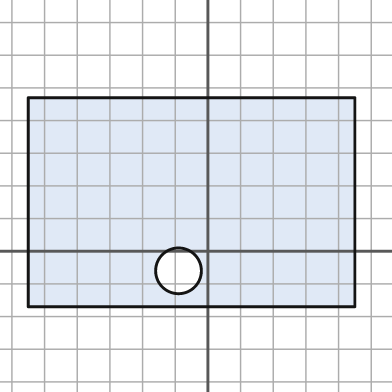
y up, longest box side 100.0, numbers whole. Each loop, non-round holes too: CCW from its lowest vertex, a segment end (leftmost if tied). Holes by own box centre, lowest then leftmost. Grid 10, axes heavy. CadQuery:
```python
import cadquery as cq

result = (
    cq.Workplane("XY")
    .moveTo(-55.0, -17.0)
    .lineTo(45.0, -17.0)
    .lineTo(45.0, 47.0)
    .lineTo(-55.0, 47.0)
    .close()
    .moveTo(-9.0, -6.0)
    .circle(7.0)
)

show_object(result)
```